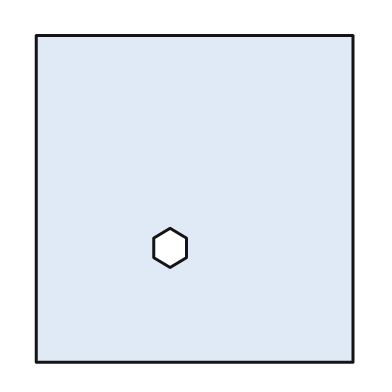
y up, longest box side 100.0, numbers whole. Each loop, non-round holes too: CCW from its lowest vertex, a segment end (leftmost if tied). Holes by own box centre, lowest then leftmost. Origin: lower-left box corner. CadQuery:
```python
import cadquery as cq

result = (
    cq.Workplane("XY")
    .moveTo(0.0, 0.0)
    .lineTo(97.0, 0.0)
    .lineTo(97.0, 100.0)
    .lineTo(0.0, 100.0)
    .close()
    .moveTo(41.0, 29.0)
    .lineTo(46.0, 32.0)
    .lineTo(46.0, 38.0)
    .lineTo(41.0, 41.0)
    .lineTo(36.0, 38.0)
    .lineTo(36.0, 32.0)
    .close()
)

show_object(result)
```